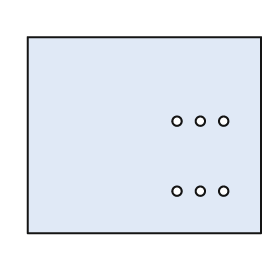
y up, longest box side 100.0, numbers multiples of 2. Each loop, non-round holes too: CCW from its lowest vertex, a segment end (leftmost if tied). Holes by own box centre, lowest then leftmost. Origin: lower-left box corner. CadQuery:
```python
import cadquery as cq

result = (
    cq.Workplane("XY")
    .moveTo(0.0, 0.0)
    .lineTo(100.0, 0.0)
    .lineTo(100.0, 84.0)
    .lineTo(0.0, 84.0)
    .close()
    .moveTo(64.0, 18.0)
    .circle(2.0)
    .moveTo(74.0, 18.0)
    .circle(2.0)
    .moveTo(84.0, 18.0)
    .circle(2.0)
    .moveTo(64.0, 48.0)
    .circle(2.0)
    .moveTo(74.0, 48.0)
    .circle(2.0)
    .moveTo(84.0, 48.0)
    .circle(2.0)
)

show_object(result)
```